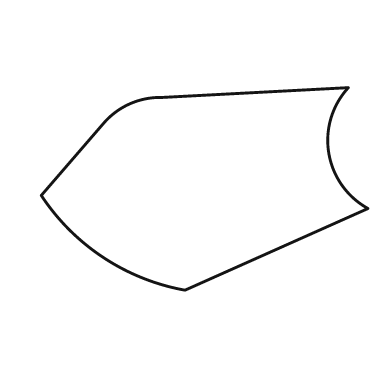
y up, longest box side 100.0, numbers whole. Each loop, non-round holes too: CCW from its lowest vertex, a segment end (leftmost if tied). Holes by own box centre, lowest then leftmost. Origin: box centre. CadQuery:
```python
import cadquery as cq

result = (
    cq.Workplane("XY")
    .moveTo(-6.0, -31.0)
    .lineTo(50.0, -6.0)
    .threePointArc((38.0, 11.0), (44.0, 31.0))
    .lineTo(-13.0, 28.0)
    .threePointArc((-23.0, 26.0), (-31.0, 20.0))
    .lineTo(-50.0, -2.0)
    .threePointArc((-31.0, -21.0), (-6.0, -31.0))
    .close()
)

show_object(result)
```